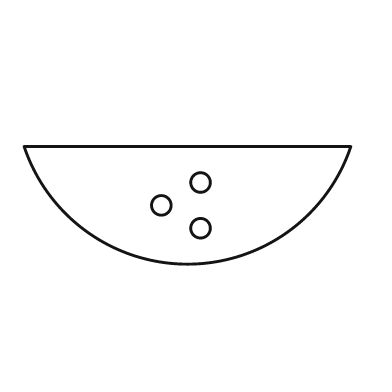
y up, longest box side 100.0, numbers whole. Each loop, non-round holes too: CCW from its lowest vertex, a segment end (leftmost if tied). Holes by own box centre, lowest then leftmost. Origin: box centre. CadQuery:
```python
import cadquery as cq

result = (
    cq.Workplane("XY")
    .moveTo(-50.0, 18.0)
    .threePointArc((0.0, -18.0), (50.0, 18.0))
    .close()
    .moveTo(4.0, -7.0)
    .circle(3.0)
    .moveTo(-8.0, 0.0)
    .circle(3.0)
    .moveTo(4.0, 7.0)
    .circle(3.0)
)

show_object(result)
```